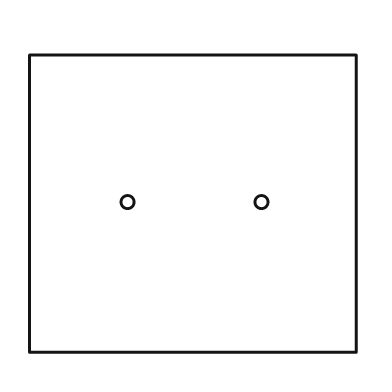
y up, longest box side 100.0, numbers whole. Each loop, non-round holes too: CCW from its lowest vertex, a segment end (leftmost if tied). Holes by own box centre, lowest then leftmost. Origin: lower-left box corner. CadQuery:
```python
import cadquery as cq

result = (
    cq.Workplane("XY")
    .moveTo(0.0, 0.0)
    .lineTo(100.0, 0.0)
    .lineTo(100.0, 91.0)
    .lineTo(0.0, 91.0)
    .close()
    .moveTo(30.0, 46.0)
    .circle(2.0)
    .moveTo(71.0, 46.0)
    .circle(2.0)
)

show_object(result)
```